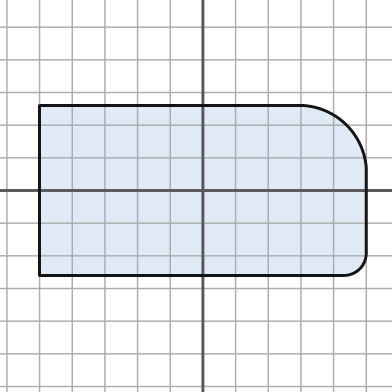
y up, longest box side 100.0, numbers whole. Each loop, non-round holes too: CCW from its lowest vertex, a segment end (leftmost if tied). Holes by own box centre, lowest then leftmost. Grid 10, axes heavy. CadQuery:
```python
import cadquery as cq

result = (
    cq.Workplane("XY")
    .moveTo(-50.0, -26.0)
    .lineTo(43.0, -26.0)
    .threePointArc((48.0, -24.0), (50.0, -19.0))
    .lineTo(50.0, 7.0)
    .threePointArc((44.0, 20.0), (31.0, 26.0))
    .lineTo(-50.0, 26.0)
    .close()
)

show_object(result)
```